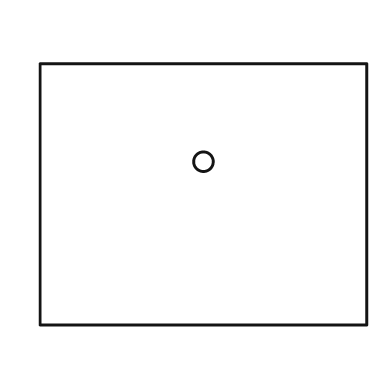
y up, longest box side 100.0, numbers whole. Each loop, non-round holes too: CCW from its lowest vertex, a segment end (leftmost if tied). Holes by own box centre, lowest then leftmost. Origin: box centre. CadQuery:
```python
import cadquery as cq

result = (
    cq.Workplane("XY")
    .moveTo(-50.0, -40.0)
    .lineTo(50.0, -40.0)
    .lineTo(50.0, 40.0)
    .lineTo(-50.0, 40.0)
    .close()
    .moveTo(0.0, 10.0)
    .circle(3.0)
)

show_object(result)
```